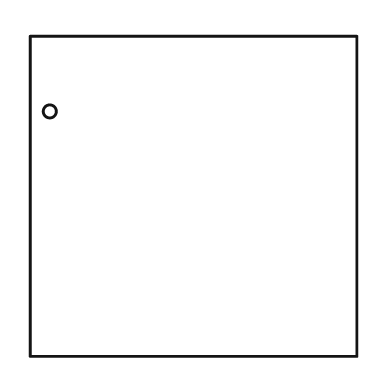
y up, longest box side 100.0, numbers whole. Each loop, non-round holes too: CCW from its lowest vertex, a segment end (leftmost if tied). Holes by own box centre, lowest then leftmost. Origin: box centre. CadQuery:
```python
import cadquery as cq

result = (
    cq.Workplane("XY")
    .moveTo(-50.0, -49.0)
    .lineTo(50.0, -49.0)
    .lineTo(50.0, 49.0)
    .lineTo(-50.0, 49.0)
    .close()
    .moveTo(-44.0, 26.0)
    .circle(2.0)
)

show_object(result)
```